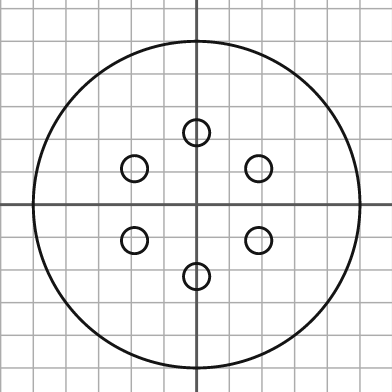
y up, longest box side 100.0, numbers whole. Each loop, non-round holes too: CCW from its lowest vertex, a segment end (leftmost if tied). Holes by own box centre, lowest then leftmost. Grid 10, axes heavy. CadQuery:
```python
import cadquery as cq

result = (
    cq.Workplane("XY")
    .moveTo(0.0, 0.0)
    .circle(50.0)
    .moveTo(0.0, -22.0)
    .circle(4.0)
    .moveTo(-19.0, -11.0)
    .circle(4.0)
    .moveTo(19.0, -11.0)
    .circle(4.0)
    .moveTo(-19.0, 11.0)
    .circle(4.0)
    .moveTo(19.0, 11.0)
    .circle(4.0)
    .moveTo(0.0, 22.0)
    .circle(4.0)
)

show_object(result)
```